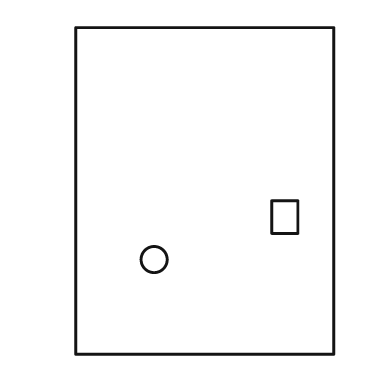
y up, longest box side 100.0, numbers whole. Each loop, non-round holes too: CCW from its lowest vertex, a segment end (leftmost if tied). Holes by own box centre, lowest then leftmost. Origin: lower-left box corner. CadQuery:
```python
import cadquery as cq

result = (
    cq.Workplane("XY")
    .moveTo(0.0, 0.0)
    .lineTo(79.0, 0.0)
    .lineTo(79.0, 100.0)
    .lineTo(0.0, 100.0)
    .close()
    .moveTo(24.0, 29.0)
    .circle(4.0)
    .moveTo(60.0, 37.0)
    .lineTo(68.0, 37.0)
    .lineTo(68.0, 47.0)
    .lineTo(60.0, 47.0)
    .close()
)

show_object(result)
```